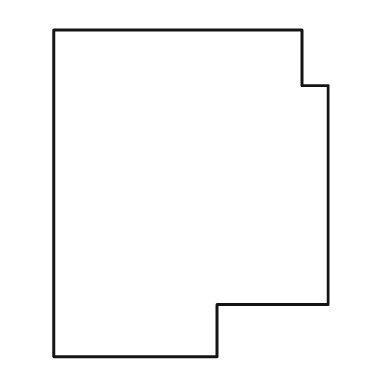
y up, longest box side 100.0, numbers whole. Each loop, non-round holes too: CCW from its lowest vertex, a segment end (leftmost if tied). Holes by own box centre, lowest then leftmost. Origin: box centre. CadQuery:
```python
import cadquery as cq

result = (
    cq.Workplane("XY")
    .moveTo(-42.0, -50.0)
    .lineTo(8.0, -50.0)
    .lineTo(8.0, -34.0)
    .lineTo(42.0, -34.0)
    .lineTo(42.0, 33.0)
    .lineTo(34.0, 33.0)
    .lineTo(34.0, 50.0)
    .lineTo(-42.0, 50.0)
    .close()
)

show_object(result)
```